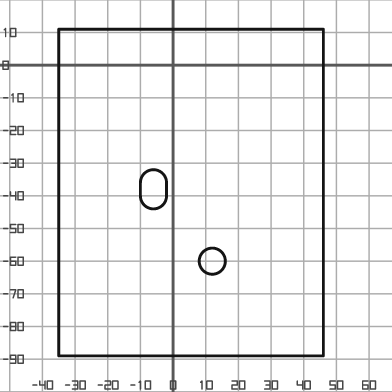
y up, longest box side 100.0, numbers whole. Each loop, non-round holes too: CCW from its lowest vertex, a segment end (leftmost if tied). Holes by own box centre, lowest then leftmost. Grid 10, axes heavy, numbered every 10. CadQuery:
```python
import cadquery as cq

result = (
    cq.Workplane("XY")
    .moveTo(-35.0, -89.0)
    .lineTo(46.0, -89.0)
    .lineTo(46.0, 11.0)
    .lineTo(-35.0, 11.0)
    .close()
    .moveTo(12.0, -60.0)
    .circle(4.0)
    .moveTo(-10.0, -40.0)
    .threePointArc((-6.0, -44.0), (-2.0, -40.0))
    .lineTo(-2.0, -36.0)
    .threePointArc((-6.0, -32.0), (-10.0, -36.0))
    .close()
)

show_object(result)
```